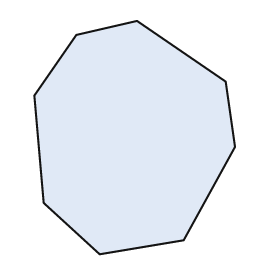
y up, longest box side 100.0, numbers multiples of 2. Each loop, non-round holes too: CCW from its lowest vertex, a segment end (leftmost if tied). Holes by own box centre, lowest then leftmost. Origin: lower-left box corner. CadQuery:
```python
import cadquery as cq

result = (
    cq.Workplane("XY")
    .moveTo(28.0, 0.0)
    .lineTo(64.0, 6.0)
    .lineTo(86.0, 46.0)
    .lineTo(82.0, 74.0)
    .lineTo(44.0, 100.0)
    .lineTo(18.0, 94.0)
    .lineTo(0.0, 68.0)
    .lineTo(4.0, 22.0)
    .close()
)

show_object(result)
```